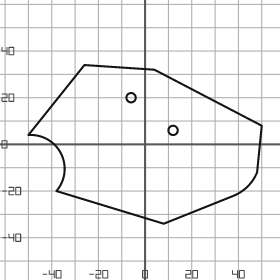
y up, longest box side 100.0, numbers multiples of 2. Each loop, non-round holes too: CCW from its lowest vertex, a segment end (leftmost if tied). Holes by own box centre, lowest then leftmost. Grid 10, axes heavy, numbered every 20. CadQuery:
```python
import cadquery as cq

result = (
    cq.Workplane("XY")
    .moveTo(8.0, -34.0)
    .lineTo(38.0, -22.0)
    .threePointArc((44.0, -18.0), (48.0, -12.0))
    .lineTo(50.0, 8.0)
    .lineTo(4.0, 32.0)
    .lineTo(-26.0, 34.0)
    .lineTo(-50.0, 4.0)
    .threePointArc((-36.0, -4.0), (-38.0, -20.0))
    .close()
    .moveTo(12.0, 6.0)
    .circle(2.0)
    .moveTo(-6.0, 20.0)
    .circle(2.0)
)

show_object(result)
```